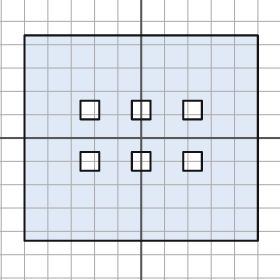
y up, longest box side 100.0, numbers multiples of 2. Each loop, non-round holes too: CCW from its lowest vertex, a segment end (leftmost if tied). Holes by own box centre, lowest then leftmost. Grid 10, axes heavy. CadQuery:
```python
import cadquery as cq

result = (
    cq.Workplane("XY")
    .moveTo(-50.0, -44.0)
    .lineTo(50.0, -44.0)
    .lineTo(50.0, 44.0)
    .lineTo(-50.0, 44.0)
    .close()
    .moveTo(-26.0, -14.0)
    .lineTo(-18.0, -14.0)
    .lineTo(-18.0, -6.0)
    .lineTo(-26.0, -6.0)
    .close()
    .moveTo(-4.0, -14.0)
    .lineTo(4.0, -14.0)
    .lineTo(4.0, -6.0)
    .lineTo(-4.0, -6.0)
    .close()
    .moveTo(18.0, -14.0)
    .lineTo(26.0, -14.0)
    .lineTo(26.0, -6.0)
    .lineTo(18.0, -6.0)
    .close()
    .moveTo(-26.0, 8.0)
    .lineTo(-18.0, 8.0)
    .lineTo(-18.0, 16.0)
    .lineTo(-26.0, 16.0)
    .close()
    .moveTo(-4.0, 8.0)
    .lineTo(4.0, 8.0)
    .lineTo(4.0, 16.0)
    .lineTo(-4.0, 16.0)
    .close()
    .moveTo(18.0, 8.0)
    .lineTo(26.0, 8.0)
    .lineTo(26.0, 16.0)
    .lineTo(18.0, 16.0)
    .close()
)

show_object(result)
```